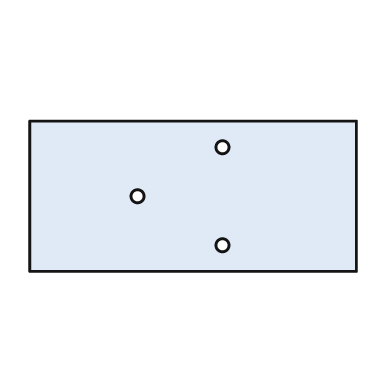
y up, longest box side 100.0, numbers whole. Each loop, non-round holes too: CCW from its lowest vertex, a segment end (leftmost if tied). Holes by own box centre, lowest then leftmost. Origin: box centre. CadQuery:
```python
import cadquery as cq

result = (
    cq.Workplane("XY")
    .moveTo(-50.0, -23.0)
    .lineTo(50.0, -23.0)
    .lineTo(50.0, 23.0)
    .lineTo(-50.0, 23.0)
    .close()
    .moveTo(9.0, -15.0)
    .circle(2.0)
    .moveTo(-17.0, 0.0)
    .circle(2.0)
    .moveTo(9.0, 15.0)
    .circle(2.0)
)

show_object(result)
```